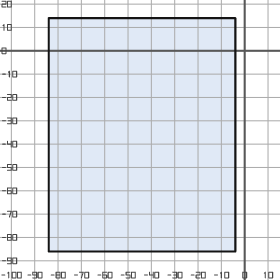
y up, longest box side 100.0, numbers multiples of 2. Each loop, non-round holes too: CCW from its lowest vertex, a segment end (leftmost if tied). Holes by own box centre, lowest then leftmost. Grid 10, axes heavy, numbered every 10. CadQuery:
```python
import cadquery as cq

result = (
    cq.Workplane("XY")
    .moveTo(-84.0, -86.0)
    .lineTo(-4.0, -86.0)
    .lineTo(-4.0, 14.0)
    .lineTo(-84.0, 14.0)
    .close()
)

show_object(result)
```